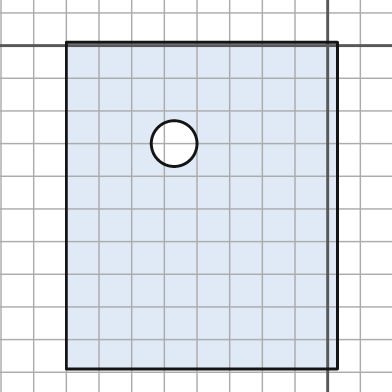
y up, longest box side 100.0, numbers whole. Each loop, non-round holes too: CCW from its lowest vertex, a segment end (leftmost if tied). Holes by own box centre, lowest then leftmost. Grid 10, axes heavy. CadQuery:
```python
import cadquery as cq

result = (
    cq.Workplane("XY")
    .moveTo(-80.0, -99.0)
    .lineTo(3.0, -99.0)
    .lineTo(3.0, 1.0)
    .lineTo(-80.0, 1.0)
    .close()
    .moveTo(-47.0, -30.0)
    .circle(7.0)
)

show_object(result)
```